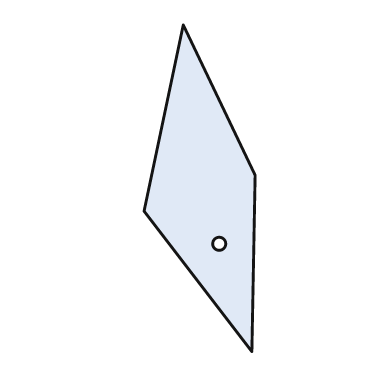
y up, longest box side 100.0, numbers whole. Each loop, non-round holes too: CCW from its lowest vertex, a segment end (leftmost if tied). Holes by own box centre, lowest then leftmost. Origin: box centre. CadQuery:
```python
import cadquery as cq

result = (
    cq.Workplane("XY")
    .moveTo(16.0, -50.0)
    .lineTo(17.0, 4.0)
    .lineTo(-5.0, 50.0)
    .lineTo(-17.0, -7.0)
    .close()
    .moveTo(6.0, -17.0)
    .circle(2.0)
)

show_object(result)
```